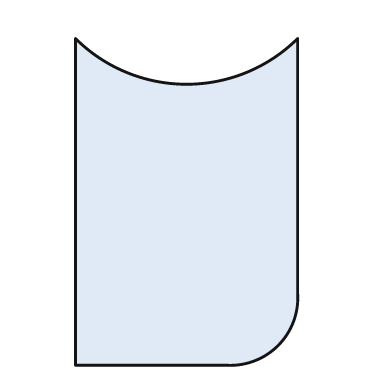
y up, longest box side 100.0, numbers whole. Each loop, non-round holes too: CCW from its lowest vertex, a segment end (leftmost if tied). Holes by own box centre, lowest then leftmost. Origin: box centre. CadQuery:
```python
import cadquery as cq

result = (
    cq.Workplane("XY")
    .moveTo(-34.0, -50.0)
    .lineTo(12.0, -50.0)
    .threePointArc((28.0, -44.0), (34.0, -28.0))
    .lineTo(34.0, 50.0)
    .threePointArc((0.0, 36.0), (-34.0, 50.0))
    .close()
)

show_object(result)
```